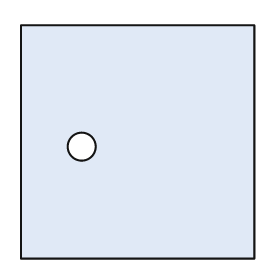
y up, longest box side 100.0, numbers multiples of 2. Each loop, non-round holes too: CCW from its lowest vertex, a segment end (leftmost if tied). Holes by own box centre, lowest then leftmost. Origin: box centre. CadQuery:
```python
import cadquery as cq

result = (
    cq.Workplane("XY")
    .moveTo(-50.0, -50.0)
    .lineTo(50.0, -50.0)
    .lineTo(50.0, 50.0)
    .lineTo(-50.0, 50.0)
    .close()
    .moveTo(-24.0, -2.0)
    .circle(6.0)
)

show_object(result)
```